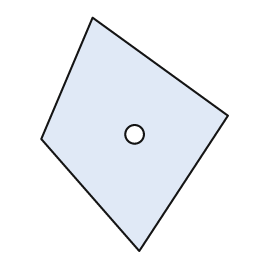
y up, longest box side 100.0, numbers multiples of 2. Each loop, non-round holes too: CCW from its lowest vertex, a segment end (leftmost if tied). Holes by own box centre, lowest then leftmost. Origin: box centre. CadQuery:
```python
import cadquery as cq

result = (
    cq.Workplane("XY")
    .moveTo(2.0, -50.0)
    .lineTo(40.0, 8.0)
    .lineTo(-18.0, 50.0)
    .lineTo(-40.0, -2.0)
    .close()
    .moveTo(0.0, 0.0)
    .circle(4.0)
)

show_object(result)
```